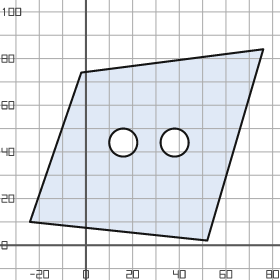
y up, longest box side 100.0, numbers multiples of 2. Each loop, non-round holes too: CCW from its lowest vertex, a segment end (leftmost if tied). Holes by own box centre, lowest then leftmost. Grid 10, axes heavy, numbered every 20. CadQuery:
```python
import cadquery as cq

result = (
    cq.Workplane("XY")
    .moveTo(52.0, 2.0)
    .lineTo(76.0, 84.0)
    .lineTo(-2.0, 74.0)
    .lineTo(-24.0, 10.0)
    .close()
    .moveTo(16.0, 44.0)
    .circle(6.0)
    .moveTo(38.0, 44.0)
    .circle(6.0)
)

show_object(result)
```